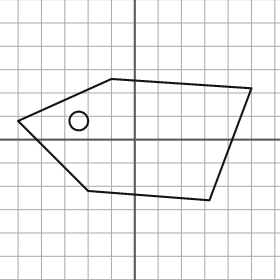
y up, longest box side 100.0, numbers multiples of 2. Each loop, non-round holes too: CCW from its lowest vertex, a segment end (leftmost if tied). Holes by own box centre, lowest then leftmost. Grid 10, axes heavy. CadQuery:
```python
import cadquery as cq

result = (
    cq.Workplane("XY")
    .moveTo(32.0, -26.0)
    .lineTo(50.0, 22.0)
    .lineTo(-10.0, 26.0)
    .lineTo(-50.0, 8.0)
    .lineTo(-20.0, -22.0)
    .close()
    .moveTo(-24.0, 8.0)
    .circle(4.0)
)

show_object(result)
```